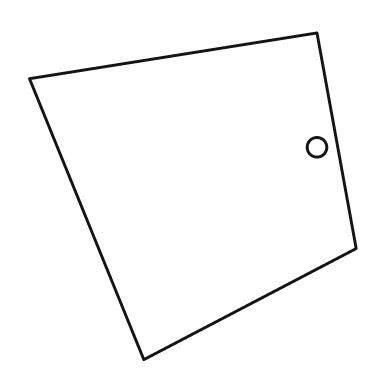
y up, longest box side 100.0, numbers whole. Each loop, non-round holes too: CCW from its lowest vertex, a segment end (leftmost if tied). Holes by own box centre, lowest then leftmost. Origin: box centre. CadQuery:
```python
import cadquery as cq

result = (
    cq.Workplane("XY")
    .moveTo(-15.0, -50.0)
    .lineTo(50.0, -16.0)
    .lineTo(38.0, 50.0)
    .lineTo(-50.0, 36.0)
    .close()
    .moveTo(38.0, 15.0)
    .circle(3.0)
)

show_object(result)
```